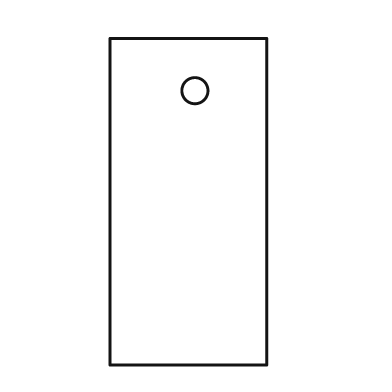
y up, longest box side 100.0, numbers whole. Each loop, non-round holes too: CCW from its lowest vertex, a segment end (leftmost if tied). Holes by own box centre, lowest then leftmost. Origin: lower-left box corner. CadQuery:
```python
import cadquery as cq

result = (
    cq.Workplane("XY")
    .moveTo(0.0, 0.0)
    .lineTo(48.0, 0.0)
    .lineTo(48.0, 100.0)
    .lineTo(0.0, 100.0)
    .close()
    .moveTo(26.0, 84.0)
    .circle(4.0)
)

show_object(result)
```